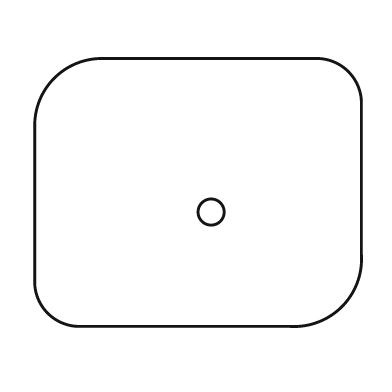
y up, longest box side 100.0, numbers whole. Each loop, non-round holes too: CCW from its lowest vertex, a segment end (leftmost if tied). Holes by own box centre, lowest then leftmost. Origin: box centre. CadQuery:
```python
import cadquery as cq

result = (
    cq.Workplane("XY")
    .moveTo(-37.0, -41.0)
    .lineTo(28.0, -41.0)
    .threePointArc((44.0, -35.0), (50.0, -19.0))
    .lineTo(50.0, 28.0)
    .threePointArc((46.0, 37.0), (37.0, 41.0))
    .lineTo(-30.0, 41.0)
    .threePointArc((-44.0, 35.0), (-50.0, 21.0))
    .lineTo(-50.0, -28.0)
    .threePointArc((-46.0, -37.0), (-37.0, -41.0))
    .close()
    .moveTo(4.0, -6.0)
    .circle(4.0)
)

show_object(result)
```